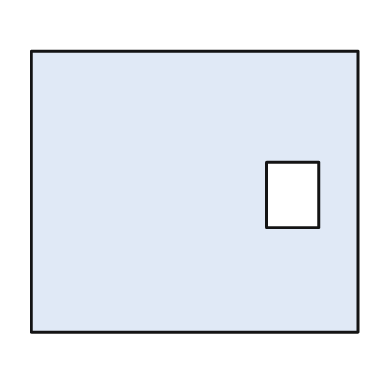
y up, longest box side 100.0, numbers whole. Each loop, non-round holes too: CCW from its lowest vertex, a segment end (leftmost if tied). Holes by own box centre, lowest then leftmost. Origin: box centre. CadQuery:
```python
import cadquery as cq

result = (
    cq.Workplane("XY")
    .moveTo(-50.0, -43.0)
    .lineTo(50.0, -43.0)
    .lineTo(50.0, 43.0)
    .lineTo(-50.0, 43.0)
    .close()
    .moveTo(22.0, -11.0)
    .lineTo(38.0, -11.0)
    .lineTo(38.0, 9.0)
    .lineTo(22.0, 9.0)
    .close()
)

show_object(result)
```